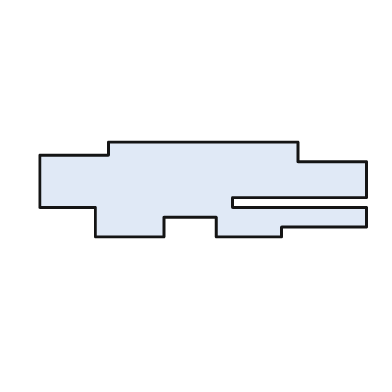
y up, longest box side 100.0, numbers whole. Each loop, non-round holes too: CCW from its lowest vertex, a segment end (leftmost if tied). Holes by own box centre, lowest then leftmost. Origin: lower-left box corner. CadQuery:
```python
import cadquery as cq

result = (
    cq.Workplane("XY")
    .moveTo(17.0, 0.0)
    .lineTo(38.0, 0.0)
    .lineTo(38.0, 6.0)
    .lineTo(54.0, 6.0)
    .lineTo(54.0, 0.0)
    .lineTo(74.0, 0.0)
    .lineTo(74.0, 3.0)
    .lineTo(100.0, 3.0)
    .lineTo(100.0, 9.0)
    .lineTo(59.0, 9.0)
    .lineTo(59.0, 12.0)
    .lineTo(100.0, 12.0)
    .lineTo(100.0, 23.0)
    .lineTo(79.0, 23.0)
    .lineTo(79.0, 29.0)
    .lineTo(21.0, 29.0)
    .lineTo(21.0, 25.0)
    .lineTo(0.0, 25.0)
    .lineTo(0.0, 9.0)
    .lineTo(17.0, 9.0)
    .close()
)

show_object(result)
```